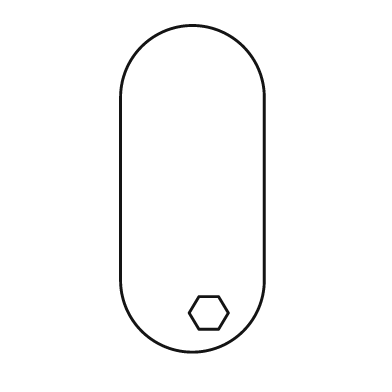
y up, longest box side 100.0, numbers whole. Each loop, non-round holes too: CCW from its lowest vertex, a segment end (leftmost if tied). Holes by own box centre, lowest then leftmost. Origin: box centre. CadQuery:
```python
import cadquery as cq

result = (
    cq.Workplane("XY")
    .moveTo(-22.0, -28.0)
    .threePointArc((0.0, -50.0), (22.0, -28.0))
    .lineTo(22.0, 28.0)
    .threePointArc((0.0, 50.0), (-22.0, 28.0))
    .close()
    .moveTo(2.0, -43.0)
    .lineTo(8.0, -43.0)
    .lineTo(11.0, -38.0)
    .lineTo(8.0, -33.0)
    .lineTo(2.0, -33.0)
    .lineTo(-1.0, -38.0)
    .close()
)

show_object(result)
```